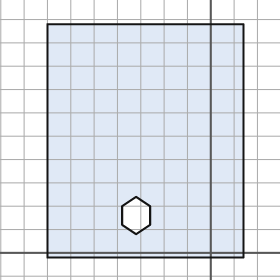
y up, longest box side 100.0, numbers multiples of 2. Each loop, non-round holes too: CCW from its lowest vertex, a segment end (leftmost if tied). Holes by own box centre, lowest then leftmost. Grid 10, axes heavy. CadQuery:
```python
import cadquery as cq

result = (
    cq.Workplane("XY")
    .moveTo(-70.0, -2.0)
    .lineTo(14.0, -2.0)
    .lineTo(14.0, 98.0)
    .lineTo(-70.0, 98.0)
    .close()
    .moveTo(-32.0, 8.0)
    .lineTo(-26.0, 12.0)
    .lineTo(-26.0, 20.0)
    .lineTo(-32.0, 24.0)
    .lineTo(-38.0, 20.0)
    .lineTo(-38.0, 12.0)
    .close()
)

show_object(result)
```